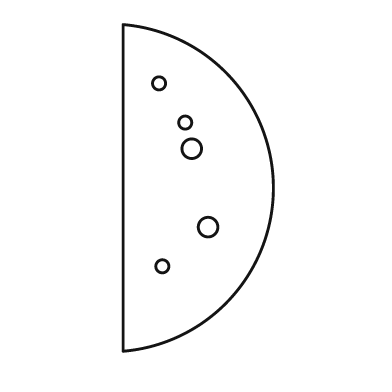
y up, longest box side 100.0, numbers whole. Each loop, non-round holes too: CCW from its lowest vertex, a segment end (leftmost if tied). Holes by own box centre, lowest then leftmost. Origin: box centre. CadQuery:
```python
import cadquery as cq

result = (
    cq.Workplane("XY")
    .moveTo(-23.0, -50.0)
    .threePointArc((23.0, 0.0), (-23.0, 50.0))
    .close()
    .moveTo(-11.0, -24.0)
    .circle(2.0)
    .moveTo(3.0, -12.0)
    .circle(3.0)
    .moveTo(-2.0, 12.0)
    .circle(3.0)
    .moveTo(-4.0, 20.0)
    .circle(2.0)
    .moveTo(-12.0, 32.0)
    .circle(2.0)
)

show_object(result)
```